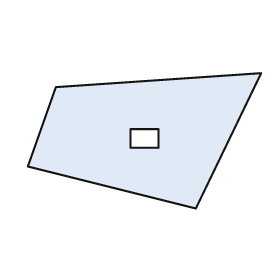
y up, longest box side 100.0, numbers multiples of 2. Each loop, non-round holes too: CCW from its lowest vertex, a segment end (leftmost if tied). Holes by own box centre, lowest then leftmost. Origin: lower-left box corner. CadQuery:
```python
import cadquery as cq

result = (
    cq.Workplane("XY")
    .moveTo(72.0, 0.0)
    .lineTo(100.0, 58.0)
    .lineTo(12.0, 52.0)
    .lineTo(0.0, 18.0)
    .close()
    .moveTo(44.0, 26.0)
    .lineTo(56.0, 26.0)
    .lineTo(56.0, 34.0)
    .lineTo(44.0, 34.0)
    .close()
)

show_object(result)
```